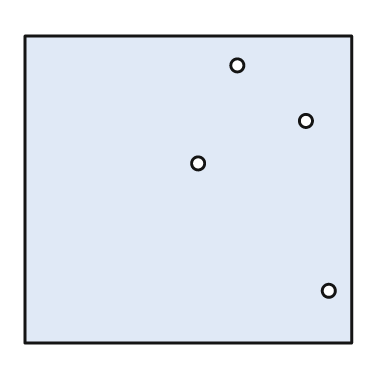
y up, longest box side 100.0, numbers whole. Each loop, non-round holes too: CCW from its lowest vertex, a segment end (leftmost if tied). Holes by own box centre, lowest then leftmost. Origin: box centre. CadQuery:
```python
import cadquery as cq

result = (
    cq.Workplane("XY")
    .moveTo(-50.0, -47.0)
    .lineTo(50.0, -47.0)
    .lineTo(50.0, 47.0)
    .lineTo(-50.0, 47.0)
    .close()
    .moveTo(43.0, -31.0)
    .circle(2.0)
    .moveTo(3.0, 8.0)
    .circle(2.0)
    .moveTo(36.0, 21.0)
    .circle(2.0)
    .moveTo(15.0, 38.0)
    .circle(2.0)
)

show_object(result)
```